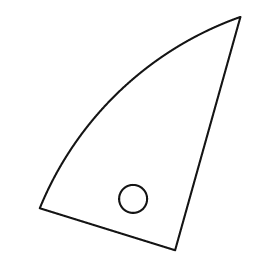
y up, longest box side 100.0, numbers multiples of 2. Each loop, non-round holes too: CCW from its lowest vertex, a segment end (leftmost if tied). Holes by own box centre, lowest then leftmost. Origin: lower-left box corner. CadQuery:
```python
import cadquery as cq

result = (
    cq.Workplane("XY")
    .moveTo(58.0, 0.0)
    .lineTo(86.0, 100.0)
    .threePointArc((34.0, 68.0), (0.0, 18.0))
    .close()
    .moveTo(40.0, 22.0)
    .circle(6.0)
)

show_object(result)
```